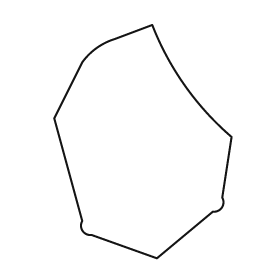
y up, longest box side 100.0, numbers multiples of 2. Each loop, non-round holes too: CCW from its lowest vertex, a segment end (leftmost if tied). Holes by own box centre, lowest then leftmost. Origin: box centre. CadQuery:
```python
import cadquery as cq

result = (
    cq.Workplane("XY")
    .moveTo(6.0, -50.0)
    .lineTo(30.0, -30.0)
    .threePointArc((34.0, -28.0), (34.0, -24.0))
    .lineTo(38.0, 2.0)
    .threePointArc((18.0, 24.0), (4.0, 50.0))
    .lineTo(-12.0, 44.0)
    .threePointArc((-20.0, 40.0), (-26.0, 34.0))
    .lineTo(-38.0, 10.0)
    .lineTo(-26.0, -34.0)
    .threePointArc((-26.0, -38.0), (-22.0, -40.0))
    .close()
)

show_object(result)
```